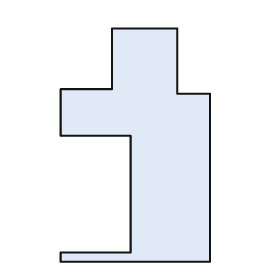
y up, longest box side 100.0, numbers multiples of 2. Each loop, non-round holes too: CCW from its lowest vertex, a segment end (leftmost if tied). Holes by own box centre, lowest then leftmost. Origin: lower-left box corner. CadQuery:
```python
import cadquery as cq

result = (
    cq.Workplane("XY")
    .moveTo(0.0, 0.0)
    .lineTo(64.0, 0.0)
    .lineTo(64.0, 72.0)
    .lineTo(50.0, 72.0)
    .lineTo(50.0, 100.0)
    .lineTo(22.0, 100.0)
    .lineTo(22.0, 74.0)
    .lineTo(0.0, 74.0)
    .lineTo(0.0, 54.0)
    .lineTo(30.0, 54.0)
    .lineTo(30.0, 4.0)
    .lineTo(0.0, 4.0)
    .close()
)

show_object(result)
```